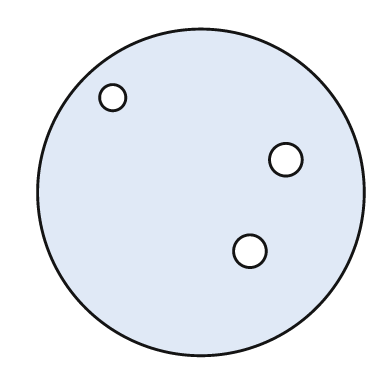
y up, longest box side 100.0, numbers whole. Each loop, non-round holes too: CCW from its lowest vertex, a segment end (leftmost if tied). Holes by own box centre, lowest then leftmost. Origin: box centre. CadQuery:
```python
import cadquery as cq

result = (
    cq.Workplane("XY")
    .moveTo(0.0, 0.0)
    .circle(50.0)
    .moveTo(15.0, -18.0)
    .circle(5.0)
    .moveTo(26.0, 10.0)
    .circle(5.0)
    .moveTo(-27.0, 29.0)
    .circle(4.0)
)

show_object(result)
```